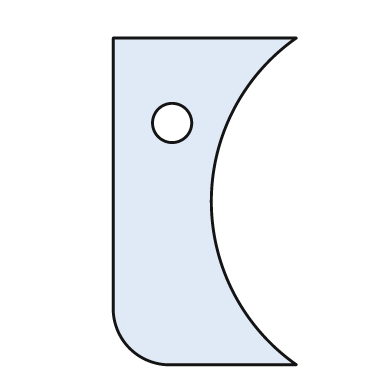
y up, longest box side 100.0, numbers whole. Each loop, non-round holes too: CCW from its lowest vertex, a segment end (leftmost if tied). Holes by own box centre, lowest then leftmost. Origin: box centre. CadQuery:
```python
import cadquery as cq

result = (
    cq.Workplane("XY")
    .moveTo(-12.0, -50.0)
    .lineTo(28.0, -50.0)
    .threePointArc((2.0, 0.0), (28.0, 50.0))
    .lineTo(-28.0, 50.0)
    .lineTo(-28.0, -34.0)
    .threePointArc((-23.0, -45.0), (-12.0, -50.0))
    .close()
    .moveTo(-10.0, 24.0)
    .circle(6.0)
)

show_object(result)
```